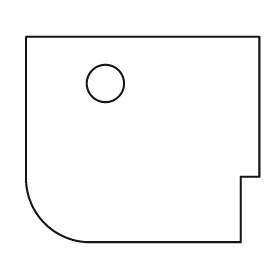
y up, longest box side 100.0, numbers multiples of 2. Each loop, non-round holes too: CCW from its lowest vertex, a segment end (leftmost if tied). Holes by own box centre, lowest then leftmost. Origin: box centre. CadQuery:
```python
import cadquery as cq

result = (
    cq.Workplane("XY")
    .moveTo(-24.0, -44.0)
    .lineTo(42.0, -44.0)
    .lineTo(42.0, -16.0)
    .lineTo(50.0, -16.0)
    .lineTo(50.0, 44.0)
    .lineTo(-50.0, 44.0)
    .lineTo(-50.0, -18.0)
    .threePointArc((-42.0, -36.0), (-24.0, -44.0))
    .close()
    .moveTo(-16.0, 24.0)
    .circle(8.0)
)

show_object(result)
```